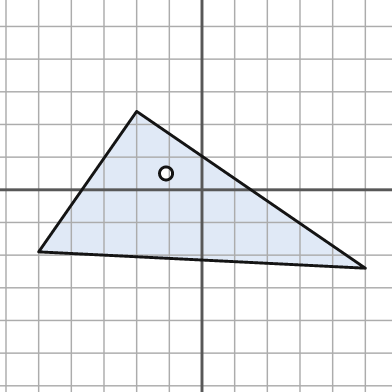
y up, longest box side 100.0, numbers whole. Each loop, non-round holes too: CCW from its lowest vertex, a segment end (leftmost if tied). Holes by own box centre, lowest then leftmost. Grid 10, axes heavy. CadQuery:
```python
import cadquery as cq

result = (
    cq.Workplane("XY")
    .moveTo(50.0, -24.0)
    .lineTo(-20.0, 24.0)
    .lineTo(-50.0, -19.0)
    .close()
    .moveTo(-11.0, 5.0)
    .circle(2.0)
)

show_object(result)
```